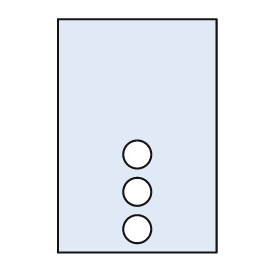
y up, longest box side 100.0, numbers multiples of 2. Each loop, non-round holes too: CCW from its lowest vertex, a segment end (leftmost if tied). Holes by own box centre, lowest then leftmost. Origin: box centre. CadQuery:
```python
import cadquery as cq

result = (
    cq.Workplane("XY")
    .moveTo(-34.0, -50.0)
    .lineTo(34.0, -50.0)
    .lineTo(34.0, 50.0)
    .lineTo(-34.0, 50.0)
    .close()
    .moveTo(0.0, -40.0)
    .circle(6.0)
    .moveTo(0.0, -24.0)
    .circle(6.0)
    .moveTo(0.0, -8.0)
    .circle(6.0)
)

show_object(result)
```